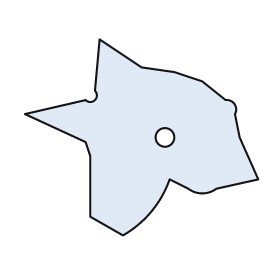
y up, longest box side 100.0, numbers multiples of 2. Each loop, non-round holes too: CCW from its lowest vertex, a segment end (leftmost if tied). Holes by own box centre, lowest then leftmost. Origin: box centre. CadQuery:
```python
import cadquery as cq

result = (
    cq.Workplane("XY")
    .moveTo(-8.0, -42.0)
    .threePointArc((4.0, -32.0), (12.0, -18.0))
    .lineTo(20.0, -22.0)
    .threePointArc((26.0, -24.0), (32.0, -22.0))
    .lineTo(50.0, -18.0)
    .lineTo(42.0, 0.0)
    .lineTo(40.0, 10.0)
    .threePointArc((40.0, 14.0), (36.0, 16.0))
    .lineTo(26.0, 24.0)
    .lineTo(14.0, 28.0)
    .lineTo(0.0, 30.0)
    .lineTo(-18.0, 42.0)
    .lineTo(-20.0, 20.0)
    .threePointArc((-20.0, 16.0), (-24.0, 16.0))
    .lineTo(-50.0, 10.0)
    .lineTo(-24.0, -2.0)
    .lineTo(-22.0, -8.0)
    .lineTo(-22.0, -34.0)
    .close()
    .moveTo(10.0, 0.0)
    .circle(4.0)
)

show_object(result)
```